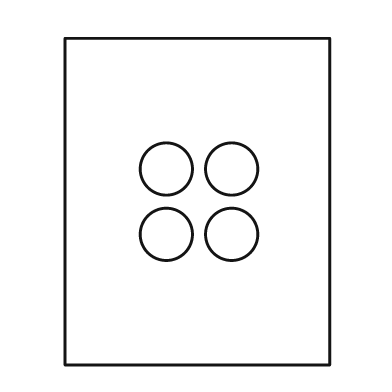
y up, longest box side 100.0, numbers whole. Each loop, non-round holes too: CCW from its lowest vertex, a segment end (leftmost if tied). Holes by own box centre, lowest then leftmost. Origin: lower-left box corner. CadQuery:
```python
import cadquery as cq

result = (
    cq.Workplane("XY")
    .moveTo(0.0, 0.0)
    .lineTo(81.0, 0.0)
    .lineTo(81.0, 100.0)
    .lineTo(0.0, 100.0)
    .close()
    .moveTo(31.0, 40.0)
    .circle(8.0)
    .moveTo(51.0, 40.0)
    .circle(8.0)
    .moveTo(31.0, 60.0)
    .circle(8.0)
    .moveTo(51.0, 60.0)
    .circle(8.0)
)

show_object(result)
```